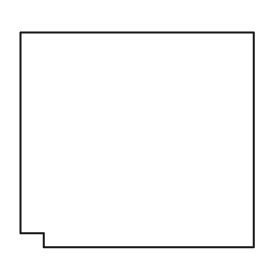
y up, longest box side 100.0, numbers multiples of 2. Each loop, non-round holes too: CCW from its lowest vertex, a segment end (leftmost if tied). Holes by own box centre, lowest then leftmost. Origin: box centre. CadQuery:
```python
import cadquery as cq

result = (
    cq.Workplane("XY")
    .moveTo(-40.0, -46.0)
    .lineTo(50.0, -46.0)
    .lineTo(50.0, 46.0)
    .lineTo(-50.0, 46.0)
    .lineTo(-50.0, -40.0)
    .lineTo(-40.0, -40.0)
    .close()
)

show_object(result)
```